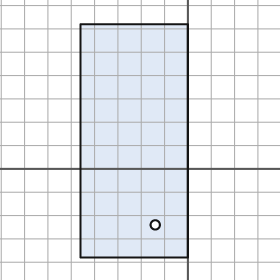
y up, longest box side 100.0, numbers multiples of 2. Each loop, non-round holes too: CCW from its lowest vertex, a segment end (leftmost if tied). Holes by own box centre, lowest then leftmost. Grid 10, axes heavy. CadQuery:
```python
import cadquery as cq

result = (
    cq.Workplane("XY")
    .moveTo(-46.0, -38.0)
    .lineTo(0.0, -38.0)
    .lineTo(0.0, 62.0)
    .lineTo(-46.0, 62.0)
    .close()
    .moveTo(-14.0, -24.0)
    .circle(2.0)
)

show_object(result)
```